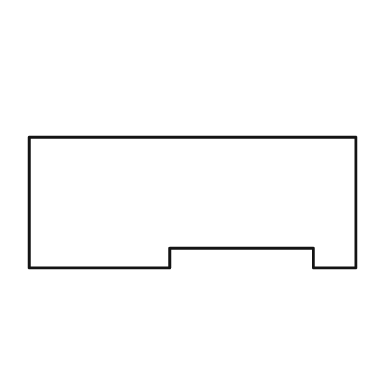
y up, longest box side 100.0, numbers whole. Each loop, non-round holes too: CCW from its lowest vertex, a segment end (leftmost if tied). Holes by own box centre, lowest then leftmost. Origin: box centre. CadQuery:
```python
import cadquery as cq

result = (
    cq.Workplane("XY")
    .moveTo(-50.0, -20.0)
    .lineTo(-7.0, -20.0)
    .lineTo(-7.0, -14.0)
    .lineTo(37.0, -14.0)
    .lineTo(37.0, -20.0)
    .lineTo(50.0, -20.0)
    .lineTo(50.0, 20.0)
    .lineTo(-50.0, 20.0)
    .close()
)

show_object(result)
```